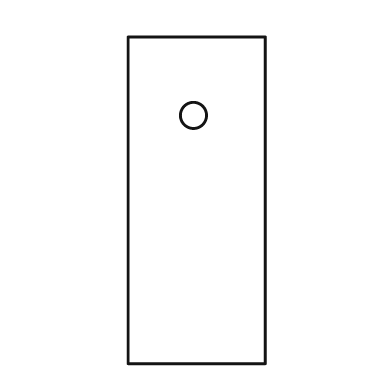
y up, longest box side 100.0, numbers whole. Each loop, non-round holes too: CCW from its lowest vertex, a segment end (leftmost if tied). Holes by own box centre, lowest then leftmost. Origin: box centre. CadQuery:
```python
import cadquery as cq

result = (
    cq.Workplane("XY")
    .moveTo(-21.0, -50.0)
    .lineTo(21.0, -50.0)
    .lineTo(21.0, 50.0)
    .lineTo(-21.0, 50.0)
    .close()
    .moveTo(-1.0, 26.0)
    .circle(4.0)
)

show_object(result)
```